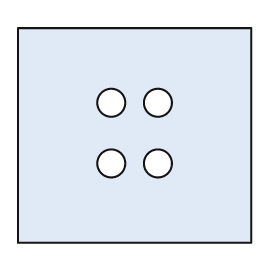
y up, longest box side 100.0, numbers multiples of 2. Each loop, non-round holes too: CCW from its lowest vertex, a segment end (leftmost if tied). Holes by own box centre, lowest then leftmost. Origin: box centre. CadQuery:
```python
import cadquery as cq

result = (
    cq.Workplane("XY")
    .moveTo(-50.0, -46.0)
    .lineTo(50.0, -46.0)
    .lineTo(50.0, 46.0)
    .lineTo(-50.0, 46.0)
    .close()
    .moveTo(-10.0, -12.0)
    .circle(6.0)
    .moveTo(10.0, -12.0)
    .circle(6.0)
    .moveTo(-10.0, 14.0)
    .circle(6.0)
    .moveTo(10.0, 14.0)
    .circle(6.0)
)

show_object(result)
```